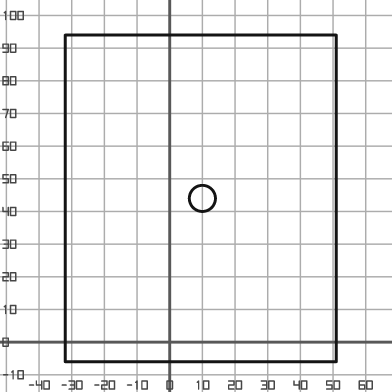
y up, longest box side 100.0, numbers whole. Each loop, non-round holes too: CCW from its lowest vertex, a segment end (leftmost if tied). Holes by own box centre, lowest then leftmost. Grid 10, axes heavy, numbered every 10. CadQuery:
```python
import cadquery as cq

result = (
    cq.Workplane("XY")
    .moveTo(-32.0, -6.0)
    .lineTo(51.0, -6.0)
    .lineTo(51.0, 94.0)
    .lineTo(-32.0, 94.0)
    .close()
    .moveTo(10.0, 44.0)
    .circle(4.0)
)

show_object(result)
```